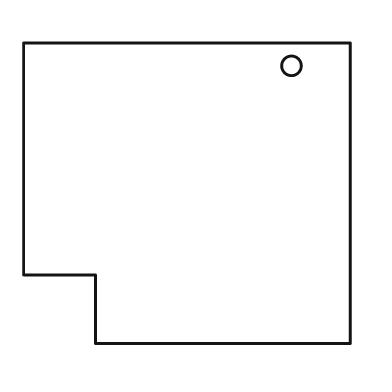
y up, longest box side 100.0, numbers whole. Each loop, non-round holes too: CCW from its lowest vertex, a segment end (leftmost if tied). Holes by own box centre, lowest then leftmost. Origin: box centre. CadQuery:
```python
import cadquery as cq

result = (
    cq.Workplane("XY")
    .moveTo(-28.0, -46.0)
    .lineTo(50.0, -46.0)
    .lineTo(50.0, 46.0)
    .lineTo(-50.0, 46.0)
    .lineTo(-50.0, -25.0)
    .lineTo(-28.0, -25.0)
    .close()
    .moveTo(32.0, 39.0)
    .circle(3.0)
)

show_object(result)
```